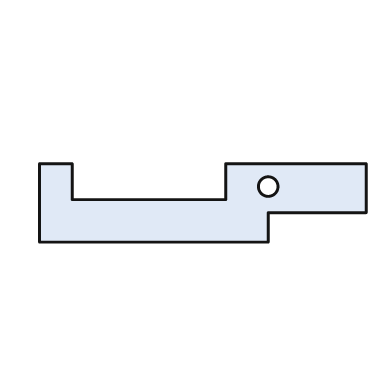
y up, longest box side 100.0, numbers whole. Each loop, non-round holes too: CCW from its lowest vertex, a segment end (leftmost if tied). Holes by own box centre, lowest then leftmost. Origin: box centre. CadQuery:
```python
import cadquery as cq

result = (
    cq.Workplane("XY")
    .moveTo(-50.0, -12.0)
    .lineTo(20.0, -12.0)
    .lineTo(20.0, -3.0)
    .lineTo(50.0, -3.0)
    .lineTo(50.0, 12.0)
    .lineTo(7.0, 12.0)
    .lineTo(7.0, 1.0)
    .lineTo(-40.0, 1.0)
    .lineTo(-40.0, 12.0)
    .lineTo(-50.0, 12.0)
    .close()
    .moveTo(20.0, 5.0)
    .circle(3.0)
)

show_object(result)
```